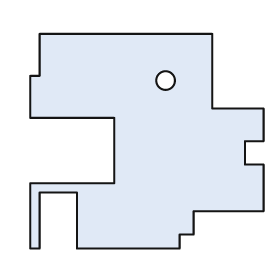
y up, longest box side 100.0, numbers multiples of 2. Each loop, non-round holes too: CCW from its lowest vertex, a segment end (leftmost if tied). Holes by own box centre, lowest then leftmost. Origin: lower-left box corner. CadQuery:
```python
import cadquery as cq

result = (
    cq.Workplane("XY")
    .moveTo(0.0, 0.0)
    .lineTo(4.0, 0.0)
    .lineTo(4.0, 24.0)
    .lineTo(20.0, 24.0)
    .lineTo(20.0, 0.0)
    .lineTo(64.0, 0.0)
    .lineTo(64.0, 6.0)
    .lineTo(70.0, 6.0)
    .lineTo(70.0, 16.0)
    .lineTo(100.0, 16.0)
    .lineTo(100.0, 36.0)
    .lineTo(92.0, 36.0)
    .lineTo(92.0, 46.0)
    .lineTo(100.0, 46.0)
    .lineTo(100.0, 60.0)
    .lineTo(78.0, 60.0)
    .lineTo(78.0, 92.0)
    .lineTo(4.0, 92.0)
    .lineTo(4.0, 74.0)
    .lineTo(0.0, 74.0)
    .lineTo(0.0, 56.0)
    .lineTo(36.0, 56.0)
    .lineTo(36.0, 28.0)
    .lineTo(0.0, 28.0)
    .close()
    .moveTo(58.0, 72.0)
    .circle(4.0)
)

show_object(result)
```